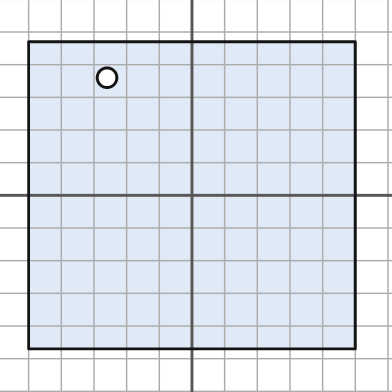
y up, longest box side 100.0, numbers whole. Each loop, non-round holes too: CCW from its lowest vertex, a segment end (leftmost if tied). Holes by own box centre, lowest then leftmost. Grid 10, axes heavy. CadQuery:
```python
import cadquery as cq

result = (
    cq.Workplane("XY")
    .moveTo(-50.0, -47.0)
    .lineTo(50.0, -47.0)
    .lineTo(50.0, 47.0)
    .lineTo(-50.0, 47.0)
    .close()
    .moveTo(-26.0, 36.0)
    .circle(3.0)
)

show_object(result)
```